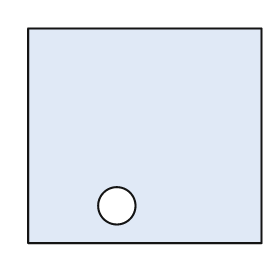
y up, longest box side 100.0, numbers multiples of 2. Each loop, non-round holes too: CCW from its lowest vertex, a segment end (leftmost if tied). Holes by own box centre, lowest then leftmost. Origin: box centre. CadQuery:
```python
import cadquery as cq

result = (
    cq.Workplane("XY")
    .moveTo(-50.0, -46.0)
    .lineTo(50.0, -46.0)
    .lineTo(50.0, 46.0)
    .lineTo(-50.0, 46.0)
    .close()
    .moveTo(-12.0, -30.0)
    .circle(8.0)
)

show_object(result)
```